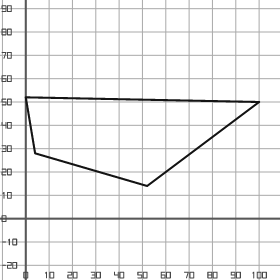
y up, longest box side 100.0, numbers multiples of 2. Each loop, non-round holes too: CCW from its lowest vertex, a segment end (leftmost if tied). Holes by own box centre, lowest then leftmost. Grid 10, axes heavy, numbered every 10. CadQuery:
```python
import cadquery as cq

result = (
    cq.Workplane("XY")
    .moveTo(52.0, 14.0)
    .lineTo(100.0, 50.0)
    .lineTo(0.0, 52.0)
    .lineTo(4.0, 28.0)
    .close()
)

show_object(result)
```